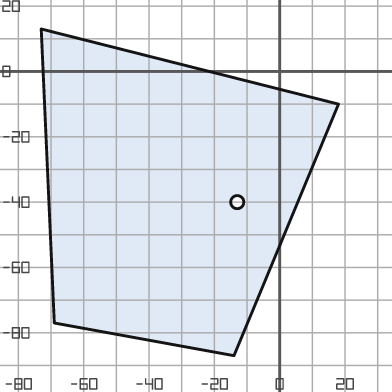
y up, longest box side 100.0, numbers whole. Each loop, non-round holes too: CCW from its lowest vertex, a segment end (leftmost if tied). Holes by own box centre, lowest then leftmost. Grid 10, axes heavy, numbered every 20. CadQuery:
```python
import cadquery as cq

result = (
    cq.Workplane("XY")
    .moveTo(-14.0, -87.0)
    .lineTo(18.0, -10.0)
    .lineTo(-73.0, 13.0)
    .lineTo(-69.0, -77.0)
    .close()
    .moveTo(-13.0, -40.0)
    .circle(2.0)
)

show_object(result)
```